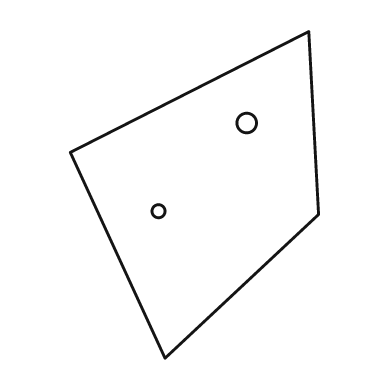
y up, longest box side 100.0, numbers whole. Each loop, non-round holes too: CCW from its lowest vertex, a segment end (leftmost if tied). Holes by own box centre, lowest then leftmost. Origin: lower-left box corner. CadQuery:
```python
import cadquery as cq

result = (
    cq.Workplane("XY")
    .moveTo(29.0, 0.0)
    .lineTo(76.0, 44.0)
    .lineTo(73.0, 100.0)
    .lineTo(0.0, 63.0)
    .close()
    .moveTo(27.0, 45.0)
    .circle(2.0)
    .moveTo(54.0, 72.0)
    .circle(3.0)
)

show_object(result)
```